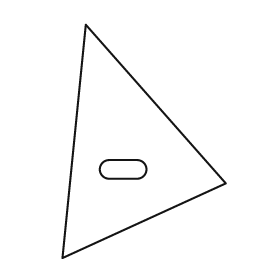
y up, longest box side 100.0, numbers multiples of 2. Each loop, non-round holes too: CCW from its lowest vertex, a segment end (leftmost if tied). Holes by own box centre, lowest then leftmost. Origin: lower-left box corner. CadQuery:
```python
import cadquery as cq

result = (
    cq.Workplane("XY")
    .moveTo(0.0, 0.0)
    .lineTo(70.0, 32.0)
    .lineTo(10.0, 100.0)
    .close()
    .moveTo(20.0, 34.0)
    .lineTo(32.0, 34.0)
    .threePointArc((36.0, 38.0), (32.0, 42.0))
    .lineTo(20.0, 42.0)
    .threePointArc((16.0, 38.0), (20.0, 34.0))
    .close()
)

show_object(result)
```